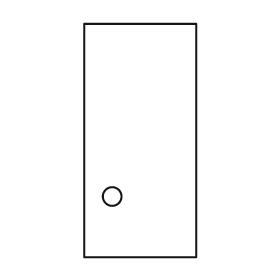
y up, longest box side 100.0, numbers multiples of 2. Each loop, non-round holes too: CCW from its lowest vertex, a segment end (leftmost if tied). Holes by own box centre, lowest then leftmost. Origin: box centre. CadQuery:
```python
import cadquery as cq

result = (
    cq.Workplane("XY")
    .moveTo(-24.0, -50.0)
    .lineTo(24.0, -50.0)
    .lineTo(24.0, 50.0)
    .lineTo(-24.0, 50.0)
    .close()
    .moveTo(-12.0, -24.0)
    .circle(4.0)
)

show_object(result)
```